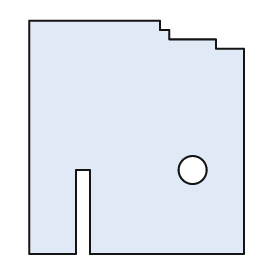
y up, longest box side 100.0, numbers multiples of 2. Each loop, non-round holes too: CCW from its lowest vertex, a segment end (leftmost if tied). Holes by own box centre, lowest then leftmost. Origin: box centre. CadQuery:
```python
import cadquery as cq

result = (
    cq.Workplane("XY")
    .moveTo(-46.0, -50.0)
    .lineTo(-26.0, -50.0)
    .lineTo(-26.0, -14.0)
    .lineTo(-20.0, -14.0)
    .lineTo(-20.0, -50.0)
    .lineTo(46.0, -50.0)
    .lineTo(46.0, 38.0)
    .lineTo(34.0, 38.0)
    .lineTo(34.0, 42.0)
    .lineTo(14.0, 42.0)
    .lineTo(14.0, 46.0)
    .lineTo(10.0, 46.0)
    .lineTo(10.0, 50.0)
    .lineTo(-46.0, 50.0)
    .close()
    .moveTo(24.0, -14.0)
    .circle(6.0)
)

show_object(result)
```